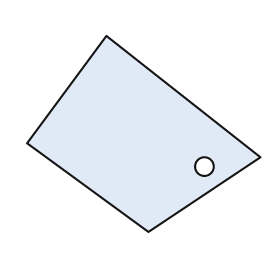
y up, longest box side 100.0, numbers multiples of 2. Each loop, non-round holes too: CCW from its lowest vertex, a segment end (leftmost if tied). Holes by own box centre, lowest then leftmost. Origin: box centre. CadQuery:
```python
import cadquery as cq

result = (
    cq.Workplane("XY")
    .moveTo(2.0, -42.0)
    .lineTo(50.0, -10.0)
    .lineTo(-16.0, 42.0)
    .lineTo(-50.0, -4.0)
    .close()
    .moveTo(26.0, -14.0)
    .circle(4.0)
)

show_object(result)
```